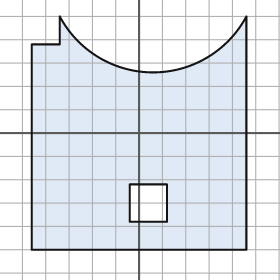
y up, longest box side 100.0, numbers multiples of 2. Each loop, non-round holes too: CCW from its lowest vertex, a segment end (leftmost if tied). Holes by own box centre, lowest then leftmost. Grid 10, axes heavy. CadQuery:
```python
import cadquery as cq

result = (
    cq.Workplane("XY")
    .moveTo(-46.0, -50.0)
    .lineTo(46.0, -50.0)
    .lineTo(46.0, 50.0)
    .threePointArc((6.0, 26.0), (-34.0, 50.0))
    .lineTo(-34.0, 38.0)
    .lineTo(-46.0, 38.0)
    .close()
    .moveTo(-4.0, -38.0)
    .lineTo(12.0, -38.0)
    .lineTo(12.0, -22.0)
    .lineTo(-4.0, -22.0)
    .close()
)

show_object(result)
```